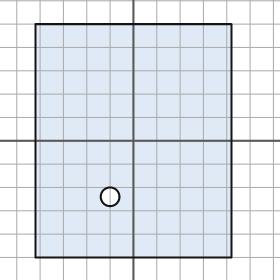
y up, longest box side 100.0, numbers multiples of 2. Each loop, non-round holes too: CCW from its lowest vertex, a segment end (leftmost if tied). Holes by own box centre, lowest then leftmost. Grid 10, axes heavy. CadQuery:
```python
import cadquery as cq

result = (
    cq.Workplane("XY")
    .moveTo(-42.0, -50.0)
    .lineTo(42.0, -50.0)
    .lineTo(42.0, 50.0)
    .lineTo(-42.0, 50.0)
    .close()
    .moveTo(-10.0, -24.0)
    .circle(4.0)
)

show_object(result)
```